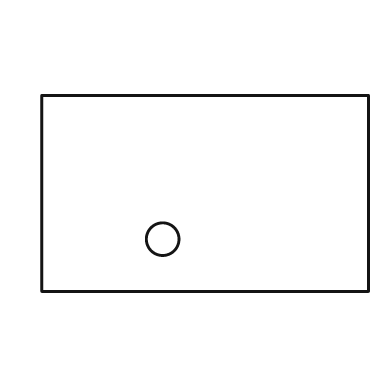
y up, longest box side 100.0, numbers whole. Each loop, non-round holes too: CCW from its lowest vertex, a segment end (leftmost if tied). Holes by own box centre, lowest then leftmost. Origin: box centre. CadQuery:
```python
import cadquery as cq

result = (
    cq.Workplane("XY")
    .moveTo(-50.0, -30.0)
    .lineTo(50.0, -30.0)
    .lineTo(50.0, 30.0)
    .lineTo(-50.0, 30.0)
    .close()
    .moveTo(-13.0, -14.0)
    .circle(5.0)
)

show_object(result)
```